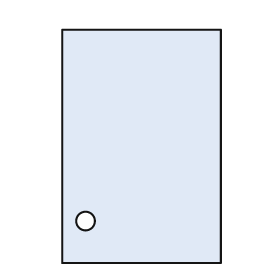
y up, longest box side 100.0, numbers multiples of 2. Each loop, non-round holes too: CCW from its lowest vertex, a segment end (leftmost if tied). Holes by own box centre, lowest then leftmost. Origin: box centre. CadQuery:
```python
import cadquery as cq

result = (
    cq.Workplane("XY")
    .moveTo(-34.0, -50.0)
    .lineTo(34.0, -50.0)
    .lineTo(34.0, 50.0)
    .lineTo(-34.0, 50.0)
    .close()
    .moveTo(-24.0, -32.0)
    .circle(4.0)
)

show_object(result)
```